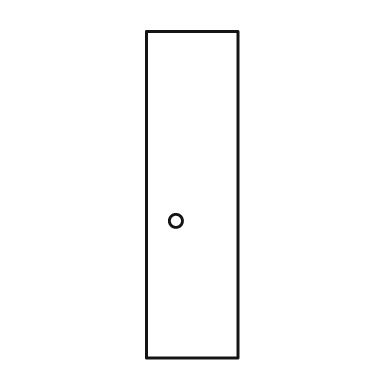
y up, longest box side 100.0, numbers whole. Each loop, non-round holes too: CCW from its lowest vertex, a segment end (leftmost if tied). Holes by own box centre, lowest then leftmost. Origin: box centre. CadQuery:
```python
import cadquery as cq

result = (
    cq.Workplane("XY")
    .moveTo(-14.0, -50.0)
    .lineTo(14.0, -50.0)
    .lineTo(14.0, 50.0)
    .lineTo(-14.0, 50.0)
    .close()
    .moveTo(-5.0, -8.0)
    .circle(2.0)
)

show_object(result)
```